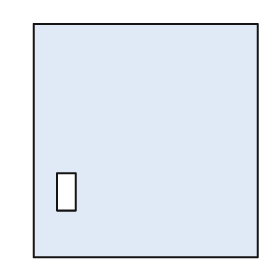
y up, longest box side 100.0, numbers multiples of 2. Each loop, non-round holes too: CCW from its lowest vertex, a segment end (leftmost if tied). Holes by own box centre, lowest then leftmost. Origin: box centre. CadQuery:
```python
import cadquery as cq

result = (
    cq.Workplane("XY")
    .moveTo(-48.0, -50.0)
    .lineTo(48.0, -50.0)
    .lineTo(48.0, 50.0)
    .lineTo(-48.0, 50.0)
    .close()
    .moveTo(-38.0, -30.0)
    .lineTo(-30.0, -30.0)
    .lineTo(-30.0, -14.0)
    .lineTo(-38.0, -14.0)
    .close()
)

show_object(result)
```